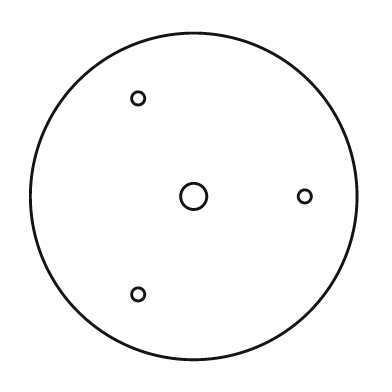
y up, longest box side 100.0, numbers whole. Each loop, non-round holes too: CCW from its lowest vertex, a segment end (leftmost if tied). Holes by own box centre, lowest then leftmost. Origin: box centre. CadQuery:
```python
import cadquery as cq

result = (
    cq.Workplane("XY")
    .moveTo(0.0, 0.0)
    .circle(50.0)
    .moveTo(-17.0, -30.0)
    .circle(2.0)
    .moveTo(0.0, 0.0)
    .circle(4.0)
    .moveTo(34.0, 0.0)
    .circle(2.0)
    .moveTo(-17.0, 30.0)
    .circle(2.0)
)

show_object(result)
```